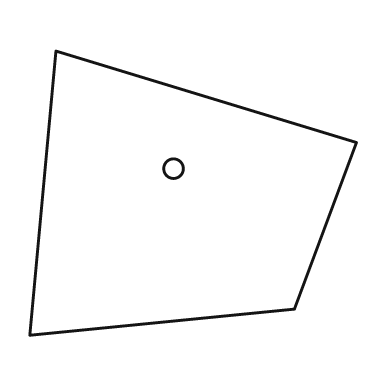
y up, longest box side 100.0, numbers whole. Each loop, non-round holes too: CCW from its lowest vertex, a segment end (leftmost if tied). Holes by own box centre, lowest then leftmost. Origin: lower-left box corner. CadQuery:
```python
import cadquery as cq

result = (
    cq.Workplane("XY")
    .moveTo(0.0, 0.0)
    .lineTo(81.0, 8.0)
    .lineTo(100.0, 59.0)
    .lineTo(8.0, 87.0)
    .close()
    .moveTo(44.0, 51.0)
    .circle(3.0)
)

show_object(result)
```